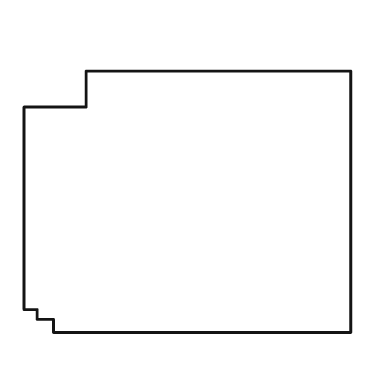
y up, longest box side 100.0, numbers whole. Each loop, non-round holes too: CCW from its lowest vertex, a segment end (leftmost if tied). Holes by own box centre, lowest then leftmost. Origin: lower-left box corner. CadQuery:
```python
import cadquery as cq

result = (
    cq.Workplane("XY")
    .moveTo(9.0, 0.0)
    .lineTo(100.0, 0.0)
    .lineTo(100.0, 80.0)
    .lineTo(19.0, 80.0)
    .lineTo(19.0, 69.0)
    .lineTo(0.0, 69.0)
    .lineTo(0.0, 7.0)
    .lineTo(4.0, 7.0)
    .lineTo(4.0, 4.0)
    .lineTo(9.0, 4.0)
    .close()
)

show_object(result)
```